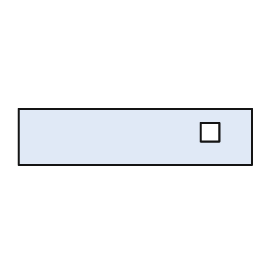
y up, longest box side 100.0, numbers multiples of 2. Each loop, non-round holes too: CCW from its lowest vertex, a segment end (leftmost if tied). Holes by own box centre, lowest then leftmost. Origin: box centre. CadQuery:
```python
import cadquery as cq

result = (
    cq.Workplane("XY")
    .moveTo(-50.0, -12.0)
    .lineTo(50.0, -12.0)
    .lineTo(50.0, 12.0)
    .lineTo(-50.0, 12.0)
    .close()
    .moveTo(28.0, -2.0)
    .lineTo(36.0, -2.0)
    .lineTo(36.0, 6.0)
    .lineTo(28.0, 6.0)
    .close()
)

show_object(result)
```